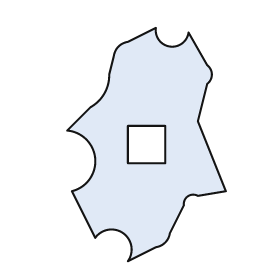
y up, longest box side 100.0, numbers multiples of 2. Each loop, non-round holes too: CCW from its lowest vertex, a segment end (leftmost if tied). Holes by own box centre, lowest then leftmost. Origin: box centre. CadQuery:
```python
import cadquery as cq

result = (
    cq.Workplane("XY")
    .moveTo(-8.0, -50.0)
    .lineTo(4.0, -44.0)
    .threePointArc((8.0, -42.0), (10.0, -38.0))
    .lineTo(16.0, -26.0)
    .threePointArc((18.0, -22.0), (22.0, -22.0))
    .lineTo(34.0, -20.0)
    .lineTo(22.0, 10.0)
    .lineTo(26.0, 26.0)
    .threePointArc((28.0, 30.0), (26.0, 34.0))
    .lineTo(18.0, 48.0)
    .threePointArc((10.0, 42.0), (4.0, 50.0))
    .lineTo(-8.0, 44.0)
    .threePointArc((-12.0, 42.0), (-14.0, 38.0))
    .lineTo(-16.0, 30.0)
    .threePointArc((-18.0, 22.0), (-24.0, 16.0))
    .lineTo(-34.0, 6.0)
    .threePointArc((-22.0, -6.0), (-32.0, -20.0))
    .lineTo(-22.0, -40.0)
    .threePointArc((-10.0, -38.0), (-8.0, -50.0))
    .close()
    .moveTo(-8.0, -8.0)
    .lineTo(8.0, -8.0)
    .lineTo(8.0, 8.0)
    .lineTo(-8.0, 8.0)
    .close()
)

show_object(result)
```